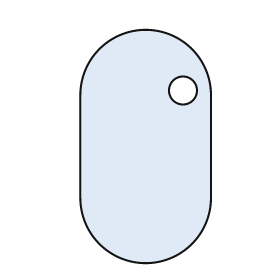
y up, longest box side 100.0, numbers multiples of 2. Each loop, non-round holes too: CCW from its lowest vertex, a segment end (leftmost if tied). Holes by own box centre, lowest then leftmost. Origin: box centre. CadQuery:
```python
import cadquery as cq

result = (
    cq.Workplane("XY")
    .moveTo(-28.0, -22.0)
    .threePointArc((0.0, -50.0), (28.0, -22.0))
    .lineTo(28.0, 22.0)
    .threePointArc((0.0, 50.0), (-28.0, 22.0))
    .close()
    .moveTo(16.0, 24.0)
    .circle(6.0)
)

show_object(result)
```